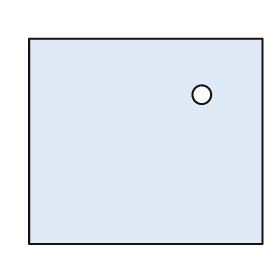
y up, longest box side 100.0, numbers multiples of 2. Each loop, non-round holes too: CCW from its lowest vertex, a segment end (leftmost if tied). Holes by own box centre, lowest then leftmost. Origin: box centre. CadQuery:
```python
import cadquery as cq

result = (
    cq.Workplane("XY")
    .moveTo(-50.0, -44.0)
    .lineTo(50.0, -44.0)
    .lineTo(50.0, 44.0)
    .lineTo(-50.0, 44.0)
    .close()
    .moveTo(24.0, 20.0)
    .circle(4.0)
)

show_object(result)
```